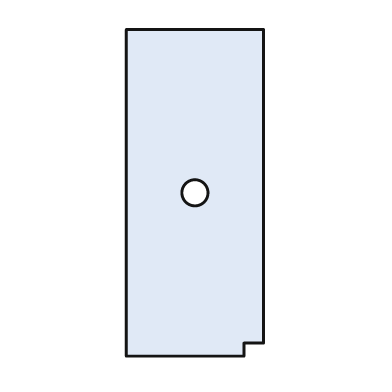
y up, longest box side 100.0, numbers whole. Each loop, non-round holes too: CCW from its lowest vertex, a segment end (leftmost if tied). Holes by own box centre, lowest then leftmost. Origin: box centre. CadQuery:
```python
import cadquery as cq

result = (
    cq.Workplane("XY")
    .moveTo(-21.0, -50.0)
    .lineTo(15.0, -50.0)
    .lineTo(15.0, -46.0)
    .lineTo(21.0, -46.0)
    .lineTo(21.0, 50.0)
    .lineTo(-21.0, 50.0)
    .close()
    .moveTo(0.0, 0.0)
    .circle(4.0)
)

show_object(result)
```